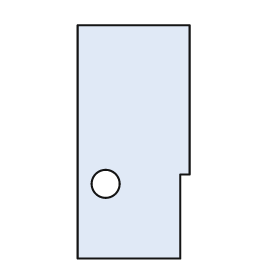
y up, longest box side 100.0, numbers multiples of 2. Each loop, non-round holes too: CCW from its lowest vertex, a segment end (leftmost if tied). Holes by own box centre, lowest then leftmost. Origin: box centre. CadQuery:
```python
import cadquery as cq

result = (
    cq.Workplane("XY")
    .moveTo(-24.0, -50.0)
    .lineTo(20.0, -50.0)
    .lineTo(20.0, -14.0)
    .lineTo(24.0, -14.0)
    .lineTo(24.0, 50.0)
    .lineTo(-24.0, 50.0)
    .close()
    .moveTo(-12.0, -18.0)
    .circle(6.0)
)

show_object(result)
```